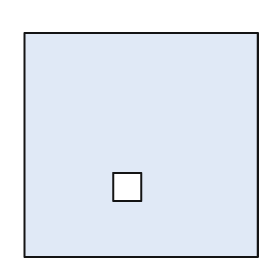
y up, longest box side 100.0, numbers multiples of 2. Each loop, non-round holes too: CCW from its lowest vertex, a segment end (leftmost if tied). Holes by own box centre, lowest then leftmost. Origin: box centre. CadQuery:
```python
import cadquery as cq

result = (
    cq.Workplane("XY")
    .moveTo(-50.0, -48.0)
    .lineTo(50.0, -48.0)
    .lineTo(50.0, 48.0)
    .lineTo(-50.0, 48.0)
    .close()
    .moveTo(-12.0, -24.0)
    .lineTo(0.0, -24.0)
    .lineTo(0.0, -12.0)
    .lineTo(-12.0, -12.0)
    .close()
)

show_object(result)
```